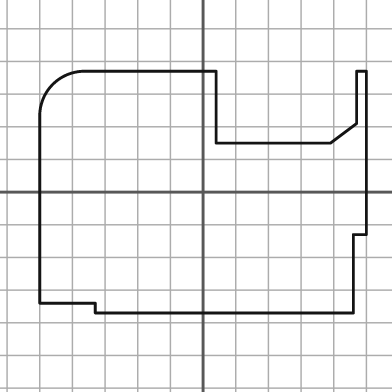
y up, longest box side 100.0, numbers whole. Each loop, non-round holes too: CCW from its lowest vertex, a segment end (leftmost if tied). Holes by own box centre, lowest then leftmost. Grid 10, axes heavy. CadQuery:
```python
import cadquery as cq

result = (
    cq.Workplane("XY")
    .moveTo(-33.0, -37.0)
    .lineTo(46.0, -37.0)
    .lineTo(46.0, -13.0)
    .lineTo(50.0, -13.0)
    .lineTo(50.0, 37.0)
    .lineTo(47.0, 37.0)
    .lineTo(47.0, 21.0)
    .lineTo(39.0, 15.0)
    .lineTo(4.0, 15.0)
    .lineTo(4.0, 37.0)
    .lineTo(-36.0, 37.0)
    .threePointArc((-46.0, 33.0), (-50.0, 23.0))
    .lineTo(-50.0, -34.0)
    .lineTo(-33.0, -34.0)
    .close()
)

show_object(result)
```